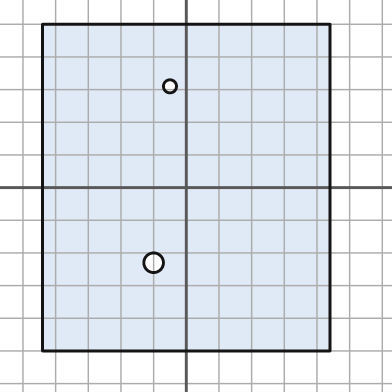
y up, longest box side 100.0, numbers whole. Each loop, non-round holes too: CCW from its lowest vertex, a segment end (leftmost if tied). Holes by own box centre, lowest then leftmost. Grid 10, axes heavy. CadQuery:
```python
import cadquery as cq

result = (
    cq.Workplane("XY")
    .moveTo(-44.0, -50.0)
    .lineTo(44.0, -50.0)
    .lineTo(44.0, 50.0)
    .lineTo(-44.0, 50.0)
    .close()
    .moveTo(-10.0, -23.0)
    .circle(3.0)
    .moveTo(-5.0, 31.0)
    .circle(2.0)
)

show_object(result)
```